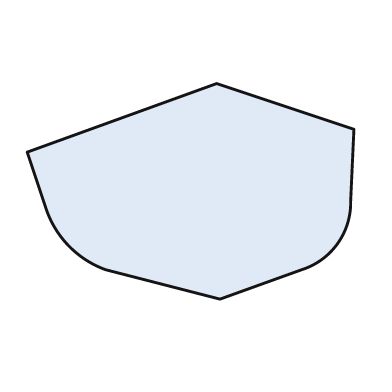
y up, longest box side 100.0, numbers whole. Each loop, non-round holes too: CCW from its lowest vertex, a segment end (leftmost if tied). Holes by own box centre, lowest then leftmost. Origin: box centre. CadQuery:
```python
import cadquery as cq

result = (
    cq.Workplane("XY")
    .moveTo(9.0, -33.0)
    .lineTo(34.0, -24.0)
    .threePointArc((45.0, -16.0), (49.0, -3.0))
    .lineTo(50.0, 19.0)
    .lineTo(8.0, 33.0)
    .lineTo(-50.0, 12.0)
    .lineTo(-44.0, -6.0)
    .threePointArc((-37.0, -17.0), (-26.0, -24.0))
    .close()
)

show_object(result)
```